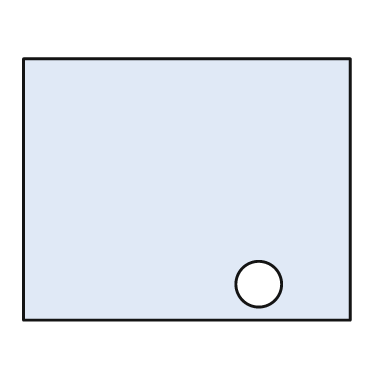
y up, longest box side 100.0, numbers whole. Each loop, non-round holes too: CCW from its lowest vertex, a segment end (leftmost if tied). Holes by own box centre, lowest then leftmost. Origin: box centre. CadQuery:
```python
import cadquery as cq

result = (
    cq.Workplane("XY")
    .moveTo(-50.0, -40.0)
    .lineTo(50.0, -40.0)
    .lineTo(50.0, 40.0)
    .lineTo(-50.0, 40.0)
    .close()
    .moveTo(22.0, -29.0)
    .circle(7.0)
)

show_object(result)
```